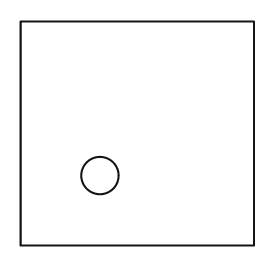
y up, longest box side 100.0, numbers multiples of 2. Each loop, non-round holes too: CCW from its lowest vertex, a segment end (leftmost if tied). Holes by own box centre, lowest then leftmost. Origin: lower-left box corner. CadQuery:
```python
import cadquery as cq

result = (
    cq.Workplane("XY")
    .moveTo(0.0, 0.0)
    .lineTo(100.0, 0.0)
    .lineTo(100.0, 96.0)
    .lineTo(0.0, 96.0)
    .close()
    .moveTo(34.0, 30.0)
    .circle(8.0)
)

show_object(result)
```